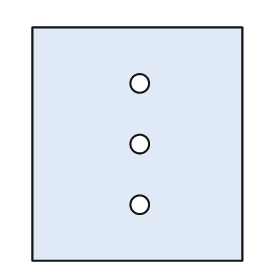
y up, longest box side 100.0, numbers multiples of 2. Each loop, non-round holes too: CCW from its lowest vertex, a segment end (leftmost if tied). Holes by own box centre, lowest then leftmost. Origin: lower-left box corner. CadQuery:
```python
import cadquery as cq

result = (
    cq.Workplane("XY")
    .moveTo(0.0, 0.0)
    .lineTo(90.0, 0.0)
    .lineTo(90.0, 100.0)
    .lineTo(0.0, 100.0)
    .close()
    .moveTo(46.0, 24.0)
    .circle(4.0)
    .moveTo(46.0, 50.0)
    .circle(4.0)
    .moveTo(46.0, 76.0)
    .circle(4.0)
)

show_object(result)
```